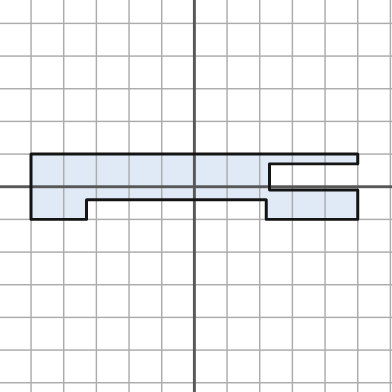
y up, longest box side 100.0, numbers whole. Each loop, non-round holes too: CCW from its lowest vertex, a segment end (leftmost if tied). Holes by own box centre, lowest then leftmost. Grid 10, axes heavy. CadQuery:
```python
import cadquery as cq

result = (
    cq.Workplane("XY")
    .moveTo(-50.0, -10.0)
    .lineTo(-33.0, -10.0)
    .lineTo(-33.0, -4.0)
    .lineTo(22.0, -4.0)
    .lineTo(22.0, -10.0)
    .lineTo(50.0, -10.0)
    .lineTo(50.0, -1.0)
    .lineTo(23.0, -1.0)
    .lineTo(23.0, 7.0)
    .lineTo(50.0, 7.0)
    .lineTo(50.0, 10.0)
    .lineTo(-50.0, 10.0)
    .close()
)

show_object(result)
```